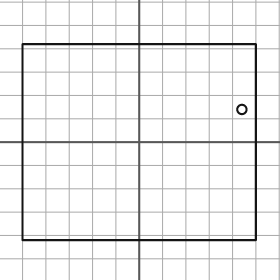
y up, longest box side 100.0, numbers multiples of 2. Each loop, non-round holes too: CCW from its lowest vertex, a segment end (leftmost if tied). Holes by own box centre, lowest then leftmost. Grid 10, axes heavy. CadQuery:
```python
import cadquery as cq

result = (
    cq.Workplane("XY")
    .moveTo(-50.0, -42.0)
    .lineTo(50.0, -42.0)
    .lineTo(50.0, 42.0)
    .lineTo(-50.0, 42.0)
    .close()
    .moveTo(44.0, 14.0)
    .circle(2.0)
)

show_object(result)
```